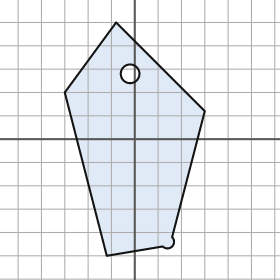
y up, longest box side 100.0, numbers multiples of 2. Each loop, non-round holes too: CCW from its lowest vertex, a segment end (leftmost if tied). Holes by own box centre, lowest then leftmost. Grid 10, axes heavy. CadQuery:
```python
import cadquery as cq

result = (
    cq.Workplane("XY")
    .moveTo(-12.0, -50.0)
    .lineTo(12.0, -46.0)
    .threePointArc((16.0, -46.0), (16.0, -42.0))
    .lineTo(30.0, 12.0)
    .lineTo(-8.0, 50.0)
    .lineTo(-30.0, 20.0)
    .close()
    .moveTo(-2.0, 28.0)
    .circle(4.0)
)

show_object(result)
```